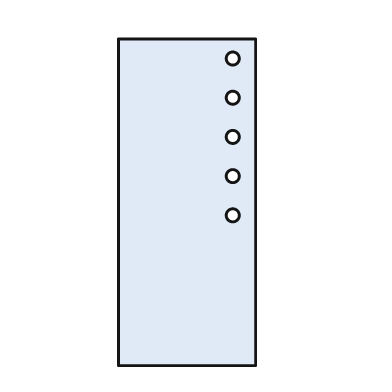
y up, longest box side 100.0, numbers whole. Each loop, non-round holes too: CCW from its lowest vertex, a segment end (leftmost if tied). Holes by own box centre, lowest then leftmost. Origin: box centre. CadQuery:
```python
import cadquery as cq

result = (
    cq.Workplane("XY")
    .moveTo(-21.0, -50.0)
    .lineTo(21.0, -50.0)
    .lineTo(21.0, 50.0)
    .lineTo(-21.0, 50.0)
    .close()
    .moveTo(14.0, -4.0)
    .circle(2.0)
    .moveTo(14.0, 8.0)
    .circle(2.0)
    .moveTo(14.0, 20.0)
    .circle(2.0)
    .moveTo(14.0, 32.0)
    .circle(2.0)
    .moveTo(14.0, 44.0)
    .circle(2.0)
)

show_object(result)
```